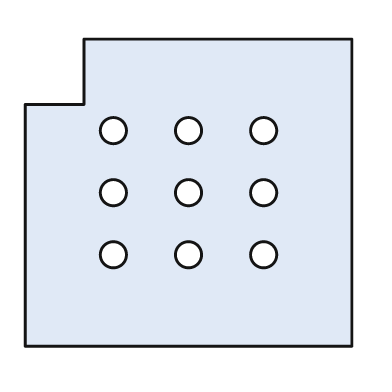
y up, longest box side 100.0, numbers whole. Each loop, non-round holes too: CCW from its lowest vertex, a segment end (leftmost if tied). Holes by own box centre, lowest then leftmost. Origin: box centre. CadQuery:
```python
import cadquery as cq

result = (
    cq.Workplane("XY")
    .moveTo(-50.0, -47.0)
    .lineTo(50.0, -47.0)
    .lineTo(50.0, 47.0)
    .lineTo(-32.0, 47.0)
    .lineTo(-32.0, 27.0)
    .lineTo(-50.0, 27.0)
    .close()
    .moveTo(-23.0, -19.0)
    .circle(4.0)
    .moveTo(0.0, -19.0)
    .circle(4.0)
    .moveTo(23.0, -19.0)
    .circle(4.0)
    .moveTo(-23.0, 0.0)
    .circle(4.0)
    .moveTo(0.0, 0.0)
    .circle(4.0)
    .moveTo(23.0, 0.0)
    .circle(4.0)
    .moveTo(-23.0, 19.0)
    .circle(4.0)
    .moveTo(0.0, 19.0)
    .circle(4.0)
    .moveTo(23.0, 19.0)
    .circle(4.0)
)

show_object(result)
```